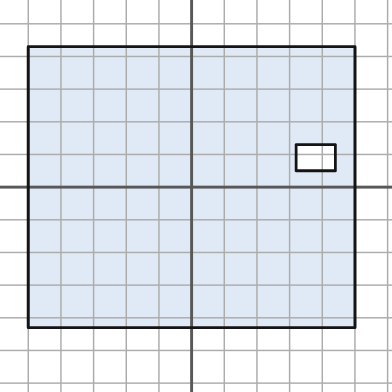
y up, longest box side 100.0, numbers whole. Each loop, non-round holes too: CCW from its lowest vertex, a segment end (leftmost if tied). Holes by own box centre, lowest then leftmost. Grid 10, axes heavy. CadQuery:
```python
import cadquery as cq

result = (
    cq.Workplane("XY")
    .moveTo(-50.0, -43.0)
    .lineTo(50.0, -43.0)
    .lineTo(50.0, 43.0)
    .lineTo(-50.0, 43.0)
    .close()
    .moveTo(32.0, 5.0)
    .lineTo(44.0, 5.0)
    .lineTo(44.0, 13.0)
    .lineTo(32.0, 13.0)
    .close()
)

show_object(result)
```